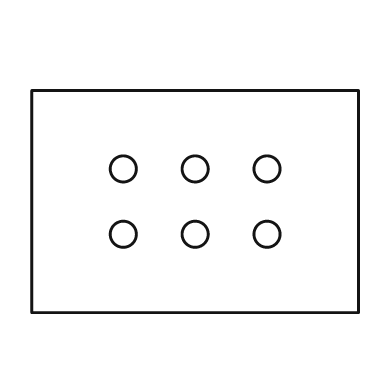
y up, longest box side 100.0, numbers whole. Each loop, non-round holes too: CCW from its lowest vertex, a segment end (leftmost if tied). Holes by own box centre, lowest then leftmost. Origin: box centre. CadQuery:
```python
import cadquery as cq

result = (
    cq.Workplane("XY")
    .moveTo(-50.0, -34.0)
    .lineTo(50.0, -34.0)
    .lineTo(50.0, 34.0)
    .lineTo(-50.0, 34.0)
    .close()
    .moveTo(-22.0, -10.0)
    .circle(4.0)
    .moveTo(0.0, -10.0)
    .circle(4.0)
    .moveTo(22.0, -10.0)
    .circle(4.0)
    .moveTo(-22.0, 10.0)
    .circle(4.0)
    .moveTo(0.0, 10.0)
    .circle(4.0)
    .moveTo(22.0, 10.0)
    .circle(4.0)
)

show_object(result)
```